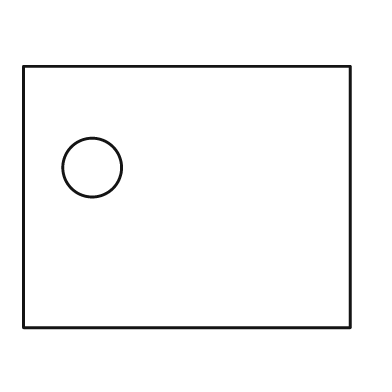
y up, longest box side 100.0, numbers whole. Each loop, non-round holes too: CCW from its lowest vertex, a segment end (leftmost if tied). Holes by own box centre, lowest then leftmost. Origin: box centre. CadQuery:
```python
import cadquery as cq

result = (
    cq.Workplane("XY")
    .moveTo(-50.0, -40.0)
    .lineTo(50.0, -40.0)
    .lineTo(50.0, 40.0)
    .lineTo(-50.0, 40.0)
    .close()
    .moveTo(-29.0, 9.0)
    .circle(9.0)
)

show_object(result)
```